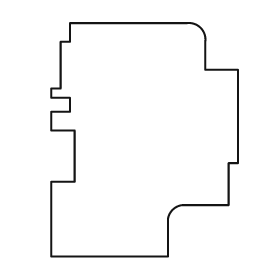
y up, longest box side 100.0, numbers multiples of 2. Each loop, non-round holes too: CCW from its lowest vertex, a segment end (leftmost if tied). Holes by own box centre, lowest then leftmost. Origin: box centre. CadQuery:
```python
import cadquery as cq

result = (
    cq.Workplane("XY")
    .moveTo(-40.0, -50.0)
    .lineTo(10.0, -50.0)
    .lineTo(10.0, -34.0)
    .threePointArc((12.0, -30.0), (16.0, -28.0))
    .lineTo(36.0, -28.0)
    .lineTo(36.0, -10.0)
    .lineTo(40.0, -10.0)
    .lineTo(40.0, 30.0)
    .lineTo(26.0, 30.0)
    .lineTo(26.0, 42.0)
    .threePointArc((24.0, 48.0), (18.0, 50.0))
    .lineTo(-32.0, 50.0)
    .lineTo(-32.0, 42.0)
    .lineTo(-36.0, 42.0)
    .lineTo(-36.0, 22.0)
    .lineTo(-40.0, 22.0)
    .lineTo(-40.0, 18.0)
    .lineTo(-32.0, 18.0)
    .lineTo(-32.0, 12.0)
    .lineTo(-40.0, 12.0)
    .lineTo(-40.0, 4.0)
    .lineTo(-30.0, 4.0)
    .lineTo(-30.0, -18.0)
    .lineTo(-40.0, -18.0)
    .close()
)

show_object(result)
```